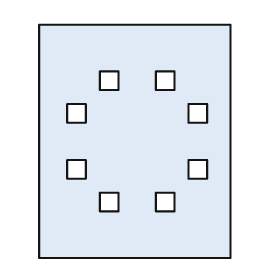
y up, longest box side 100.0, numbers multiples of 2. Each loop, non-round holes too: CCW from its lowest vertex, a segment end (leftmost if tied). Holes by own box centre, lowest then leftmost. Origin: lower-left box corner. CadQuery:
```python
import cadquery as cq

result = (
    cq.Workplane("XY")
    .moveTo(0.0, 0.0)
    .lineTo(82.0, 0.0)
    .lineTo(82.0, 100.0)
    .lineTo(0.0, 100.0)
    .close()
    .moveTo(26.0, 20.0)
    .lineTo(34.0, 20.0)
    .lineTo(34.0, 28.0)
    .lineTo(26.0, 28.0)
    .close()
    .moveTo(50.0, 20.0)
    .lineTo(58.0, 20.0)
    .lineTo(58.0, 28.0)
    .lineTo(50.0, 28.0)
    .close()
    .moveTo(12.0, 34.0)
    .lineTo(20.0, 34.0)
    .lineTo(20.0, 42.0)
    .lineTo(12.0, 42.0)
    .close()
    .moveTo(64.0, 34.0)
    .lineTo(72.0, 34.0)
    .lineTo(72.0, 42.0)
    .lineTo(64.0, 42.0)
    .close()
    .moveTo(12.0, 58.0)
    .lineTo(20.0, 58.0)
    .lineTo(20.0, 66.0)
    .lineTo(12.0, 66.0)
    .close()
    .moveTo(64.0, 58.0)
    .lineTo(72.0, 58.0)
    .lineTo(72.0, 66.0)
    .lineTo(64.0, 66.0)
    .close()
    .moveTo(26.0, 72.0)
    .lineTo(34.0, 72.0)
    .lineTo(34.0, 80.0)
    .lineTo(26.0, 80.0)
    .close()
    .moveTo(50.0, 72.0)
    .lineTo(58.0, 72.0)
    .lineTo(58.0, 80.0)
    .lineTo(50.0, 80.0)
    .close()
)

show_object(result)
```